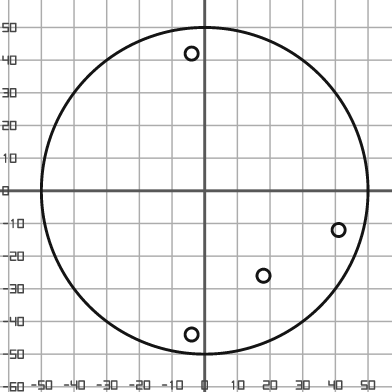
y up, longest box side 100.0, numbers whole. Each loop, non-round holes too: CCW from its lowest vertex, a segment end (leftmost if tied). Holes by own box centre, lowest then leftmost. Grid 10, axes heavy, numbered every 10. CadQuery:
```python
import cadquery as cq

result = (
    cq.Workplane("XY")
    .moveTo(0.0, 0.0)
    .circle(50.0)
    .moveTo(-4.0, -44.0)
    .circle(2.0)
    .moveTo(18.0, -26.0)
    .circle(2.0)
    .moveTo(41.0, -12.0)
    .circle(2.0)
    .moveTo(-4.0, 42.0)
    .circle(2.0)
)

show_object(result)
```